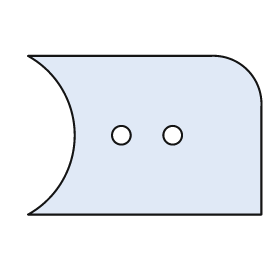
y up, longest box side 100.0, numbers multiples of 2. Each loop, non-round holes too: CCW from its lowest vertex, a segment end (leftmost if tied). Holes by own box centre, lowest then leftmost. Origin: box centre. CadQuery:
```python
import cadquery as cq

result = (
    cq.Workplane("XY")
    .moveTo(-50.0, -34.0)
    .lineTo(50.0, -34.0)
    .lineTo(50.0, 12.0)
    .threePointArc((44.0, 28.0), (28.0, 34.0))
    .lineTo(-50.0, 34.0)
    .threePointArc((-30.0, 0.0), (-50.0, -34.0))
    .close()
    .moveTo(-10.0, 0.0)
    .circle(4.0)
    .moveTo(12.0, 0.0)
    .circle(4.0)
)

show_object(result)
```